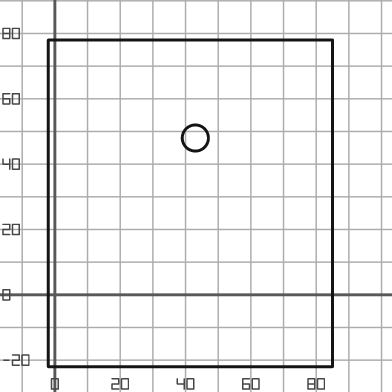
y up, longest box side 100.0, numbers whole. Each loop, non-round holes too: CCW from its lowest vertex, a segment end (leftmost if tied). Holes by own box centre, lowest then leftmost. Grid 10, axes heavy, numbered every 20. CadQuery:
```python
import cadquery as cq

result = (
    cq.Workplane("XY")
    .moveTo(-2.0, -22.0)
    .lineTo(85.0, -22.0)
    .lineTo(85.0, 78.0)
    .lineTo(-2.0, 78.0)
    .close()
    .moveTo(43.0, 48.0)
    .circle(4.0)
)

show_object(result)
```